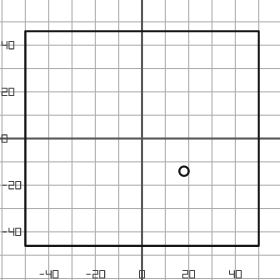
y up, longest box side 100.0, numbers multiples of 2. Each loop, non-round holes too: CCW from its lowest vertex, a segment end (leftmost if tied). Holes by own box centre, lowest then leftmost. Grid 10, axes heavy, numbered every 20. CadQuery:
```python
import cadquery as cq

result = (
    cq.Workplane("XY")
    .moveTo(-50.0, -46.0)
    .lineTo(50.0, -46.0)
    .lineTo(50.0, 46.0)
    .lineTo(-50.0, 46.0)
    .close()
    .moveTo(18.0, -14.0)
    .circle(2.0)
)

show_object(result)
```